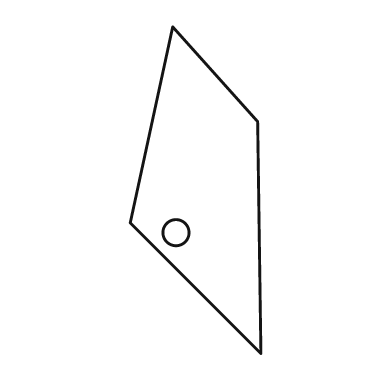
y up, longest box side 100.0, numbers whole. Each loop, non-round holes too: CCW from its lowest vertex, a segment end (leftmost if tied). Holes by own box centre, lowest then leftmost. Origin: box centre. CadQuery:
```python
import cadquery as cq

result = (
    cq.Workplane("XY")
    .moveTo(20.0, -50.0)
    .lineTo(19.0, 21.0)
    .lineTo(-7.0, 50.0)
    .lineTo(-20.0, -10.0)
    .close()
    .moveTo(-6.0, -13.0)
    .circle(4.0)
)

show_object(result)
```